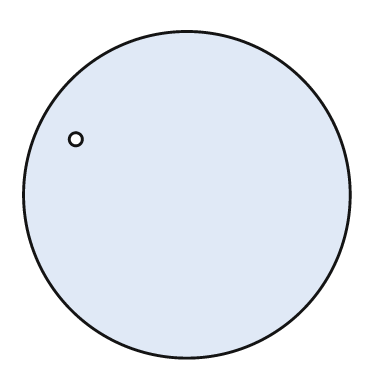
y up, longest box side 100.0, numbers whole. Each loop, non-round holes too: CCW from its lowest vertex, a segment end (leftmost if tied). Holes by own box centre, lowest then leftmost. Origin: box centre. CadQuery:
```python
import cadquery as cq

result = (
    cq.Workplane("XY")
    .moveTo(0.0, 0.0)
    .circle(50.0)
    .moveTo(-34.0, 17.0)
    .circle(2.0)
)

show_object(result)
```